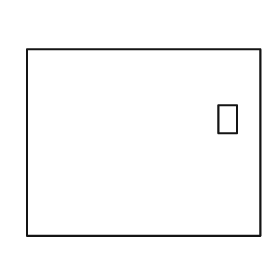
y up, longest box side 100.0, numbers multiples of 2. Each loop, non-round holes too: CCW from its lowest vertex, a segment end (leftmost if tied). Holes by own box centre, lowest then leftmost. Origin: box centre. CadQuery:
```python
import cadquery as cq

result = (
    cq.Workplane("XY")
    .moveTo(-50.0, -40.0)
    .lineTo(50.0, -40.0)
    .lineTo(50.0, 40.0)
    .lineTo(-50.0, 40.0)
    .close()
    .moveTo(32.0, 4.0)
    .lineTo(40.0, 4.0)
    .lineTo(40.0, 16.0)
    .lineTo(32.0, 16.0)
    .close()
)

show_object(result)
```